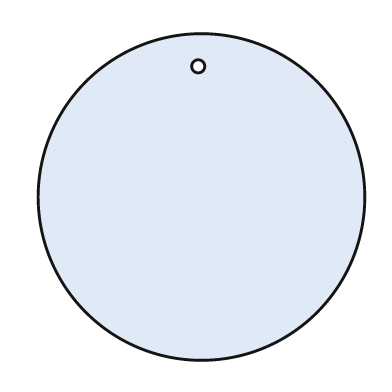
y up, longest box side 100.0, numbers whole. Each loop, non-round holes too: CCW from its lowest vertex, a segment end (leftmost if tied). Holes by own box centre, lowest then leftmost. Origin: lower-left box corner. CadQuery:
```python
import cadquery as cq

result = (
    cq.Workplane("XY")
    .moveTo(50.0, 50.0)
    .circle(50.0)
    .moveTo(49.0, 90.0)
    .circle(2.0)
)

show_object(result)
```